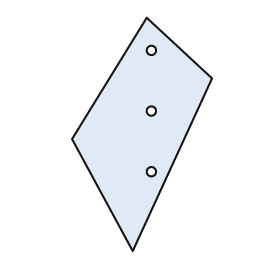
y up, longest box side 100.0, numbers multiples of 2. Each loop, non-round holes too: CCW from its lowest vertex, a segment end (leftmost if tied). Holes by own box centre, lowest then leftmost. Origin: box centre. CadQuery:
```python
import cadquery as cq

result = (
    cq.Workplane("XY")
    .moveTo(-4.0, -50.0)
    .lineTo(30.0, 24.0)
    .lineTo(2.0, 50.0)
    .lineTo(-30.0, -2.0)
    .close()
    .moveTo(4.0, -16.0)
    .circle(2.0)
    .moveTo(4.0, 10.0)
    .circle(2.0)
    .moveTo(4.0, 36.0)
    .circle(2.0)
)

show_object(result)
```